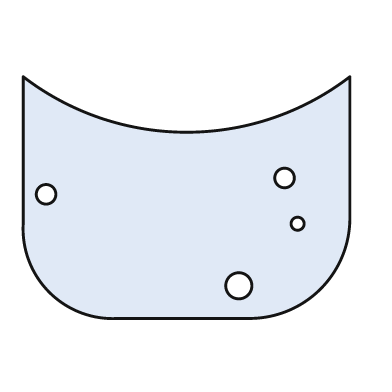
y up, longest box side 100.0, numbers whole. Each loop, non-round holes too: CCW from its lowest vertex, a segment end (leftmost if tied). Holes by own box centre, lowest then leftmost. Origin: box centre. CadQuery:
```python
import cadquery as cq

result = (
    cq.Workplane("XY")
    .moveTo(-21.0, -37.0)
    .lineTo(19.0, -37.0)
    .threePointArc((41.0, -28.0), (50.0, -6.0))
    .lineTo(50.0, 37.0)
    .threePointArc((0.0, 20.0), (-50.0, 37.0))
    .lineTo(-50.0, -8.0)
    .threePointArc((-42.0, -29.0), (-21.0, -37.0))
    .close()
    .moveTo(16.0, -27.0)
    .circle(4.0)
    .moveTo(34.0, -8.0)
    .circle(2.0)
    .moveTo(-43.0, 1.0)
    .circle(3.0)
    .moveTo(30.0, 6.0)
    .circle(3.0)
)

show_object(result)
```